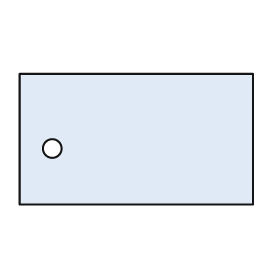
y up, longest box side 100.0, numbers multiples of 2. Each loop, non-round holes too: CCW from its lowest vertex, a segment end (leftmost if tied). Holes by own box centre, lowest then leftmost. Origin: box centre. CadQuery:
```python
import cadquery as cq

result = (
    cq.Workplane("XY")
    .moveTo(-50.0, -28.0)
    .lineTo(50.0, -28.0)
    .lineTo(50.0, 28.0)
    .lineTo(-50.0, 28.0)
    .close()
    .moveTo(-36.0, -4.0)
    .circle(4.0)
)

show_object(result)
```